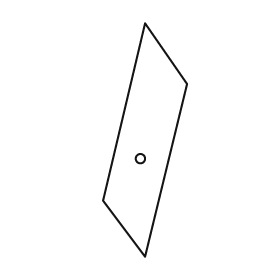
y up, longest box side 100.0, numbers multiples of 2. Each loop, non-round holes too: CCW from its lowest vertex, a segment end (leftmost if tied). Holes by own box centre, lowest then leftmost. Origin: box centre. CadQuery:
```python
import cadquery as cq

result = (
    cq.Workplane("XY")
    .moveTo(0.0, -50.0)
    .lineTo(18.0, 24.0)
    .lineTo(0.0, 50.0)
    .lineTo(-18.0, -26.0)
    .close()
    .moveTo(-2.0, -8.0)
    .circle(2.0)
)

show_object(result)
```